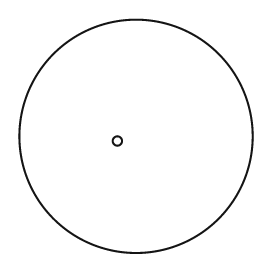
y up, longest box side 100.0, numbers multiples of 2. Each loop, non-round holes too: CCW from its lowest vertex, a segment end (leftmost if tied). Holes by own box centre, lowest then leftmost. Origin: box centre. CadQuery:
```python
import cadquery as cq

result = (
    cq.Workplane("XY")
    .moveTo(0.0, 0.0)
    .circle(50.0)
    .moveTo(-8.0, -2.0)
    .circle(2.0)
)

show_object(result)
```